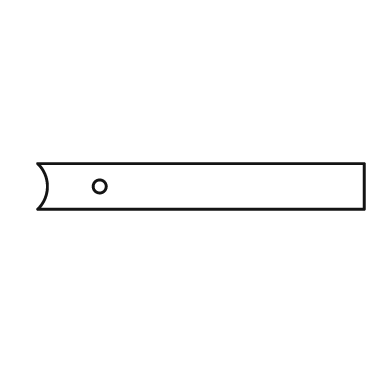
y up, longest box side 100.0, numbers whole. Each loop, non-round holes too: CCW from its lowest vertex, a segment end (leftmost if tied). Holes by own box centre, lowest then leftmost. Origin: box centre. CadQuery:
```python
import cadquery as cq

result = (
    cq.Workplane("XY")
    .moveTo(-50.0, -7.0)
    .lineTo(50.0, -7.0)
    .lineTo(50.0, 7.0)
    .lineTo(-50.0, 7.0)
    .threePointArc((-47.0, 0.0), (-50.0, -7.0))
    .close()
    .moveTo(-31.0, 0.0)
    .circle(2.0)
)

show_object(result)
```